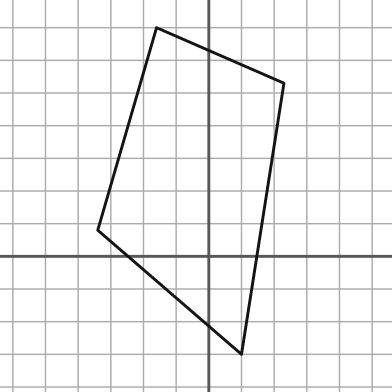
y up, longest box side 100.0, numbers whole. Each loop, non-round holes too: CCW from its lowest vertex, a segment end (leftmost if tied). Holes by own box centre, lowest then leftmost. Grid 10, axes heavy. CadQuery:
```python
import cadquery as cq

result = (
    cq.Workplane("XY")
    .moveTo(10.0, -30.0)
    .lineTo(23.0, 53.0)
    .lineTo(-16.0, 70.0)
    .lineTo(-34.0, 8.0)
    .close()
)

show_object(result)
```